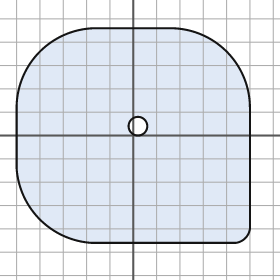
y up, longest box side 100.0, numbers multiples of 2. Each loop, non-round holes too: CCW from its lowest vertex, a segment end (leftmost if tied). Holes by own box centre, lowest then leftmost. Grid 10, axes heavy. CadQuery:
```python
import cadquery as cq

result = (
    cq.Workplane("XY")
    .moveTo(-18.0, -46.0)
    .lineTo(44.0, -46.0)
    .threePointArc((48.0, -44.0), (50.0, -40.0))
    .lineTo(50.0, 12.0)
    .threePointArc((40.0, 36.0), (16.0, 46.0))
    .lineTo(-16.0, 46.0)
    .threePointArc((-40.0, 36.0), (-50.0, 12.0))
    .lineTo(-50.0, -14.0)
    .threePointArc((-40.0, -36.0), (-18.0, -46.0))
    .close()
    .moveTo(2.0, 4.0)
    .circle(4.0)
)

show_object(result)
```